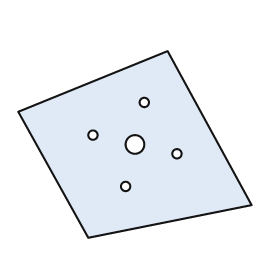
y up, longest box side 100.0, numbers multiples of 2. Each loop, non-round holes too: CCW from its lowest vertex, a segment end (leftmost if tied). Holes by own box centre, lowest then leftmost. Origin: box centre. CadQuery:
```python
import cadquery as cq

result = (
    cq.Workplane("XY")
    .moveTo(-20.0, -40.0)
    .lineTo(50.0, -26.0)
    .lineTo(14.0, 40.0)
    .lineTo(-50.0, 14.0)
    .close()
    .moveTo(-4.0, -18.0)
    .circle(2.0)
    .moveTo(18.0, -4.0)
    .circle(2.0)
    .moveTo(0.0, 0.0)
    .circle(4.0)
    .moveTo(-18.0, 4.0)
    .circle(2.0)
    .moveTo(4.0, 18.0)
    .circle(2.0)
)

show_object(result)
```